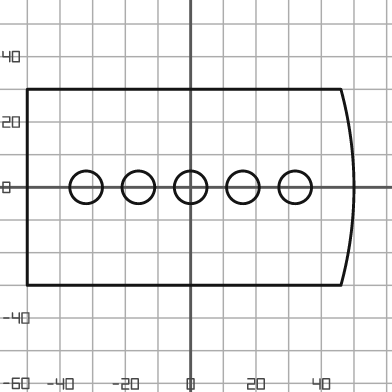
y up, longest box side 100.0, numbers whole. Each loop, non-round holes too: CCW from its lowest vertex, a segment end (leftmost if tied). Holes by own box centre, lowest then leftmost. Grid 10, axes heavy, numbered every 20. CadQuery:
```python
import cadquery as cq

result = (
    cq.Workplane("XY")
    .moveTo(-50.0, -30.0)
    .lineTo(46.0, -30.0)
    .threePointArc((50.0, 0.0), (46.0, 30.0))
    .lineTo(-50.0, 30.0)
    .close()
    .moveTo(-32.0, 0.0)
    .circle(5.0)
    .moveTo(-16.0, 0.0)
    .circle(5.0)
    .moveTo(0.0, 0.0)
    .circle(5.0)
    .moveTo(16.0, 0.0)
    .circle(5.0)
    .moveTo(32.0, 0.0)
    .circle(5.0)
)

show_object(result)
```